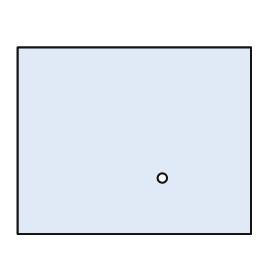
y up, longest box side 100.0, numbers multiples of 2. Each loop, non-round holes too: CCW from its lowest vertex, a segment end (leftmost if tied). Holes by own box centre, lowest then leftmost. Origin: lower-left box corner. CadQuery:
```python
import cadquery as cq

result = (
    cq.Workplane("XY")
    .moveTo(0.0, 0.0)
    .lineTo(100.0, 0.0)
    .lineTo(100.0, 80.0)
    .lineTo(0.0, 80.0)
    .close()
    .moveTo(62.0, 24.0)
    .circle(2.0)
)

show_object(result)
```